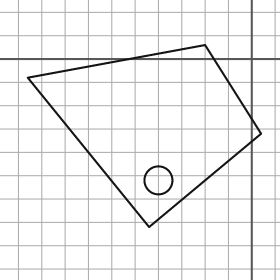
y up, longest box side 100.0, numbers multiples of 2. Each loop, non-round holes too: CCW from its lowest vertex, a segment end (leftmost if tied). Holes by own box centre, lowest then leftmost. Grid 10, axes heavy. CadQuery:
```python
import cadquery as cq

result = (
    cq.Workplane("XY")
    .moveTo(-44.0, -72.0)
    .lineTo(4.0, -32.0)
    .lineTo(-20.0, 6.0)
    .lineTo(-96.0, -8.0)
    .close()
    .moveTo(-40.0, -52.0)
    .circle(6.0)
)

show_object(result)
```